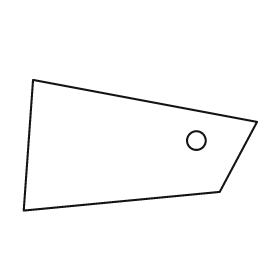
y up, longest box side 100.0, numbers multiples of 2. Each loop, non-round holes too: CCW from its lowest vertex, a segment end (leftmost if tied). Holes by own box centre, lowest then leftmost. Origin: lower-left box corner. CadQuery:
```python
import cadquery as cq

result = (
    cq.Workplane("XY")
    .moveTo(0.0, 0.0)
    .lineTo(84.0, 8.0)
    .lineTo(100.0, 38.0)
    .lineTo(4.0, 56.0)
    .close()
    .moveTo(74.0, 30.0)
    .circle(4.0)
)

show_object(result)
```